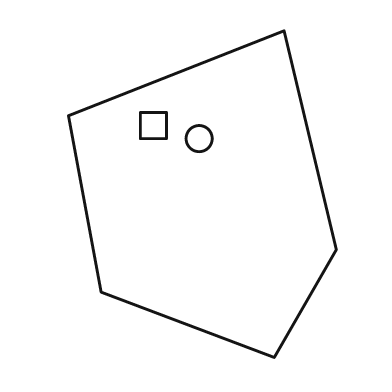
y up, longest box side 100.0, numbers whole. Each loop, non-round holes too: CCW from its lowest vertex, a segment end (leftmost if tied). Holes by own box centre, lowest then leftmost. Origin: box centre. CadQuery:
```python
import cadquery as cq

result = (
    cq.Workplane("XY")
    .moveTo(22.0, -50.0)
    .lineTo(41.0, -17.0)
    .lineTo(25.0, 50.0)
    .lineTo(-41.0, 24.0)
    .lineTo(-31.0, -30.0)
    .close()
    .moveTo(-1.0, 17.0)
    .circle(4.0)
    .moveTo(-19.0, 17.0)
    .lineTo(-11.0, 17.0)
    .lineTo(-11.0, 25.0)
    .lineTo(-19.0, 25.0)
    .close()
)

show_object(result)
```